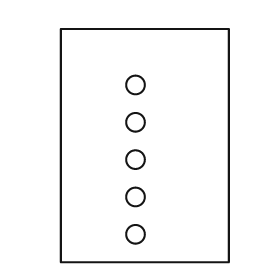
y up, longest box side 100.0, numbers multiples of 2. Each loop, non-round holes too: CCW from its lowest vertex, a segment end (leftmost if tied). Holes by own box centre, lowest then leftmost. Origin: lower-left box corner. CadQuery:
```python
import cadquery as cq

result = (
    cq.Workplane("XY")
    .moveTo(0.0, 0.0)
    .lineTo(72.0, 0.0)
    .lineTo(72.0, 100.0)
    .lineTo(0.0, 100.0)
    .close()
    .moveTo(32.0, 12.0)
    .circle(4.0)
    .moveTo(32.0, 28.0)
    .circle(4.0)
    .moveTo(32.0, 44.0)
    .circle(4.0)
    .moveTo(32.0, 60.0)
    .circle(4.0)
    .moveTo(32.0, 76.0)
    .circle(4.0)
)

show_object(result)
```